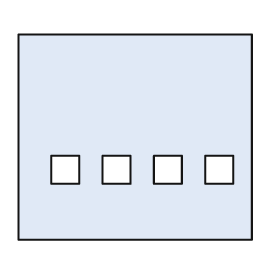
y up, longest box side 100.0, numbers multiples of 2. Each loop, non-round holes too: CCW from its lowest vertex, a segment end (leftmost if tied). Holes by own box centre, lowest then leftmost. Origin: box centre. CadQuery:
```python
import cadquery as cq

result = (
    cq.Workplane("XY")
    .moveTo(-50.0, -44.0)
    .lineTo(50.0, -44.0)
    .lineTo(50.0, 44.0)
    .lineTo(-50.0, 44.0)
    .close()
    .moveTo(-36.0, -20.0)
    .lineTo(-24.0, -20.0)
    .lineTo(-24.0, -8.0)
    .lineTo(-36.0, -8.0)
    .close()
    .moveTo(-14.0, -20.0)
    .lineTo(-2.0, -20.0)
    .lineTo(-2.0, -8.0)
    .lineTo(-14.0, -8.0)
    .close()
    .moveTo(8.0, -20.0)
    .lineTo(20.0, -20.0)
    .lineTo(20.0, -8.0)
    .lineTo(8.0, -8.0)
    .close()
    .moveTo(30.0, -20.0)
    .lineTo(42.0, -20.0)
    .lineTo(42.0, -8.0)
    .lineTo(30.0, -8.0)
    .close()
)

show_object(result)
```